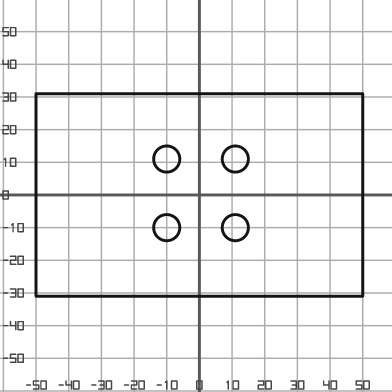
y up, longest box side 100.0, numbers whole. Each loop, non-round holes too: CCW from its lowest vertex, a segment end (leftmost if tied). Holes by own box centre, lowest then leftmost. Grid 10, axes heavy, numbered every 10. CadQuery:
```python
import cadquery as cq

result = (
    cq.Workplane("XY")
    .moveTo(-50.0, -31.0)
    .lineTo(50.0, -31.0)
    .lineTo(50.0, 31.0)
    .lineTo(-50.0, 31.0)
    .close()
    .moveTo(-10.0, -10.0)
    .circle(4.0)
    .moveTo(11.0, -10.0)
    .circle(4.0)
    .moveTo(-10.0, 11.0)
    .circle(4.0)
    .moveTo(11.0, 11.0)
    .circle(4.0)
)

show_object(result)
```